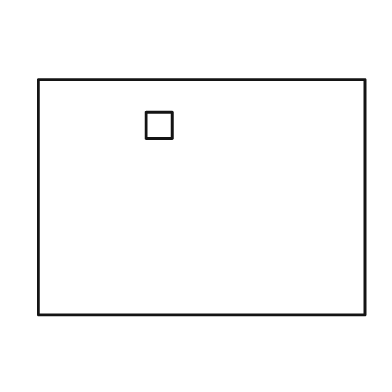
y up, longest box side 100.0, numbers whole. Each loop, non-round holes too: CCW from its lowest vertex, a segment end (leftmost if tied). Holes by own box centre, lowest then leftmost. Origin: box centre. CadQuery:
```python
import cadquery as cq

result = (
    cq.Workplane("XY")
    .moveTo(-50.0, -36.0)
    .lineTo(50.0, -36.0)
    .lineTo(50.0, 36.0)
    .lineTo(-50.0, 36.0)
    .close()
    .moveTo(-17.0, 18.0)
    .lineTo(-9.0, 18.0)
    .lineTo(-9.0, 26.0)
    .lineTo(-17.0, 26.0)
    .close()
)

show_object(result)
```